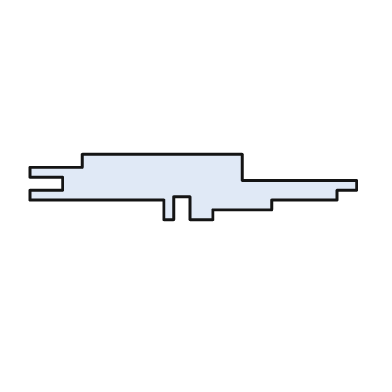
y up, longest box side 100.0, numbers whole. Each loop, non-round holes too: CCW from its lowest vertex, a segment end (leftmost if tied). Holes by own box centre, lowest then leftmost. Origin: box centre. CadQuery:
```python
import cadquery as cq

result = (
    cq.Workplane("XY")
    .moveTo(-9.0, -10.0)
    .lineTo(-6.0, -10.0)
    .lineTo(-6.0, -3.0)
    .lineTo(-1.0, -3.0)
    .lineTo(-1.0, -10.0)
    .lineTo(6.0, -10.0)
    .lineTo(6.0, -7.0)
    .lineTo(24.0, -7.0)
    .lineTo(24.0, -4.0)
    .lineTo(44.0, -4.0)
    .lineTo(44.0, -1.0)
    .lineTo(50.0, -1.0)
    .lineTo(50.0, 2.0)
    .lineTo(15.0, 2.0)
    .lineTo(15.0, 10.0)
    .lineTo(-34.0, 10.0)
    .lineTo(-34.0, 6.0)
    .lineTo(-50.0, 6.0)
    .lineTo(-50.0, 3.0)
    .lineTo(-40.0, 3.0)
    .lineTo(-40.0, -1.0)
    .lineTo(-50.0, -1.0)
    .lineTo(-50.0, -4.0)
    .lineTo(-9.0, -4.0)
    .close()
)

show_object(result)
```